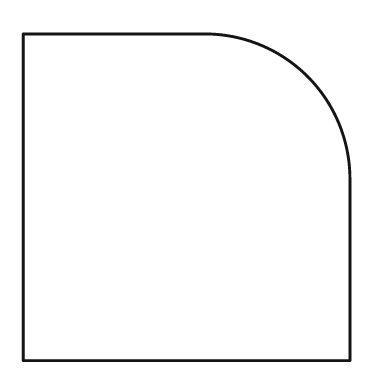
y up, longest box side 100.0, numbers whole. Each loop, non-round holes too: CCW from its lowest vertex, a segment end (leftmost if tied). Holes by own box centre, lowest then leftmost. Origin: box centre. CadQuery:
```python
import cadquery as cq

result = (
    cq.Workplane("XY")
    .moveTo(-50.0, -50.0)
    .lineTo(50.0, -50.0)
    .lineTo(50.0, 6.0)
    .threePointArc((37.0, 37.0), (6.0, 50.0))
    .lineTo(-50.0, 50.0)
    .close()
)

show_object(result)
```